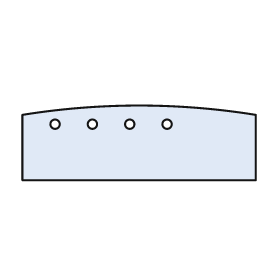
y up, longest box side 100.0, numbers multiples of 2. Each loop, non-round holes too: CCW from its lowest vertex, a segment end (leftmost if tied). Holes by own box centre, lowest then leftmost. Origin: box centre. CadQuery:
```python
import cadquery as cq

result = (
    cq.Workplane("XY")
    .moveTo(-50.0, -16.0)
    .lineTo(50.0, -16.0)
    .lineTo(50.0, 12.0)
    .threePointArc((0.0, 16.0), (-50.0, 12.0))
    .close()
    .moveTo(-36.0, 8.0)
    .circle(2.0)
    .moveTo(-20.0, 8.0)
    .circle(2.0)
    .moveTo(-4.0, 8.0)
    .circle(2.0)
    .moveTo(12.0, 8.0)
    .circle(2.0)
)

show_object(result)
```